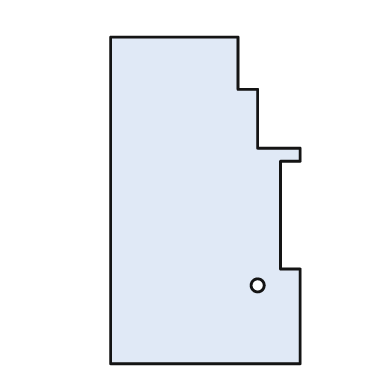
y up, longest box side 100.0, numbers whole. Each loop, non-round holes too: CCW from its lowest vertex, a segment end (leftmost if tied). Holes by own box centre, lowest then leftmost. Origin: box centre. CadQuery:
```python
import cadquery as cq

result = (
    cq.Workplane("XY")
    .moveTo(-29.0, -50.0)
    .lineTo(29.0, -50.0)
    .lineTo(29.0, -21.0)
    .lineTo(23.0, -21.0)
    .lineTo(23.0, 12.0)
    .lineTo(29.0, 12.0)
    .lineTo(29.0, 16.0)
    .lineTo(16.0, 16.0)
    .lineTo(16.0, 34.0)
    .lineTo(10.0, 34.0)
    .lineTo(10.0, 50.0)
    .lineTo(-29.0, 50.0)
    .close()
    .moveTo(16.0, -26.0)
    .circle(2.0)
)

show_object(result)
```